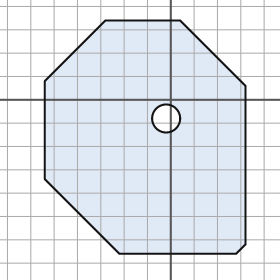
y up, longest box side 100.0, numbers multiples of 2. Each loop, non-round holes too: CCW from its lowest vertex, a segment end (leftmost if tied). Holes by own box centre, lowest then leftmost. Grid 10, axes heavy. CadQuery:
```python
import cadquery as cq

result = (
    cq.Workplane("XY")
    .moveTo(-22.0, -66.0)
    .lineTo(28.0, -66.0)
    .lineTo(32.0, -62.0)
    .lineTo(32.0, 6.0)
    .lineTo(4.0, 34.0)
    .lineTo(-28.0, 34.0)
    .lineTo(-54.0, 8.0)
    .lineTo(-54.0, -34.0)
    .close()
    .moveTo(-2.0, -8.0)
    .circle(6.0)
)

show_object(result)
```